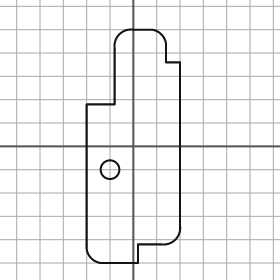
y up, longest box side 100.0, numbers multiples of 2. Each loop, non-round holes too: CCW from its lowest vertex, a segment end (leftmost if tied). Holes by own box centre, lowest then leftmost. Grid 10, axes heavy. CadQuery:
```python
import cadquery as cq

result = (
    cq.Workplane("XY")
    .moveTo(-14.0, -50.0)
    .lineTo(2.0, -50.0)
    .lineTo(2.0, -42.0)
    .lineTo(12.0, -42.0)
    .threePointArc((18.0, -40.0), (20.0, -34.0))
    .lineTo(20.0, 36.0)
    .lineTo(14.0, 36.0)
    .lineTo(14.0, 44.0)
    .threePointArc((12.0, 48.0), (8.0, 50.0))
    .lineTo(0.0, 50.0)
    .threePointArc((-6.0, 48.0), (-8.0, 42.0))
    .lineTo(-8.0, 18.0)
    .lineTo(-20.0, 18.0)
    .lineTo(-20.0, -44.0)
    .threePointArc((-18.0, -48.0), (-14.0, -50.0))
    .close()
    .moveTo(-10.0, -10.0)
    .circle(4.0)
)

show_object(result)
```